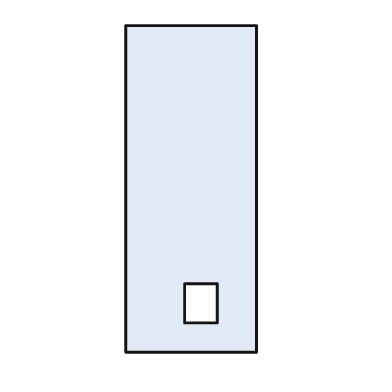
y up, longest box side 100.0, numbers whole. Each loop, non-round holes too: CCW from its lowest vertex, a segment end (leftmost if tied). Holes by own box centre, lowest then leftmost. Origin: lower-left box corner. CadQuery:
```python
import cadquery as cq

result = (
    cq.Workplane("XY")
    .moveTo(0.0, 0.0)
    .lineTo(40.0, 0.0)
    .lineTo(40.0, 100.0)
    .lineTo(0.0, 100.0)
    .close()
    .moveTo(18.0, 9.0)
    .lineTo(28.0, 9.0)
    .lineTo(28.0, 21.0)
    .lineTo(18.0, 21.0)
    .close()
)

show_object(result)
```